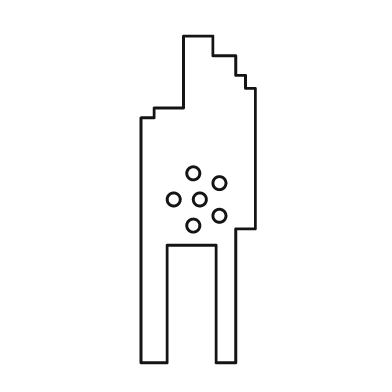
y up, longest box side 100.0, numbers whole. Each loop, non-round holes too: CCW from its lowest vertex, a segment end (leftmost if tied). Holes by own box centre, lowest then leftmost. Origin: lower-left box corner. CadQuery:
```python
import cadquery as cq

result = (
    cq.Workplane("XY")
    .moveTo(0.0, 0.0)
    .lineTo(8.0, 0.0)
    .lineTo(8.0, 36.0)
    .lineTo(23.0, 36.0)
    .lineTo(23.0, 0.0)
    .lineTo(29.0, 0.0)
    .lineTo(29.0, 41.0)
    .lineTo(35.0, 41.0)
    .lineTo(35.0, 84.0)
    .lineTo(32.0, 84.0)
    .lineTo(32.0, 88.0)
    .lineTo(29.0, 88.0)
    .lineTo(29.0, 94.0)
    .lineTo(22.0, 94.0)
    .lineTo(22.0, 100.0)
    .lineTo(13.0, 100.0)
    .lineTo(13.0, 78.0)
    .lineTo(4.0, 78.0)
    .lineTo(4.0, 75.0)
    .lineTo(0.0, 75.0)
    .close()
    .moveTo(16.0, 42.0)
    .circle(2.0)
    .moveTo(24.0, 45.0)
    .circle(2.0)
    .moveTo(10.0, 50.0)
    .circle(2.0)
    .moveTo(18.0, 50.0)
    .circle(2.0)
    .moveTo(24.0, 55.0)
    .circle(2.0)
    .moveTo(16.0, 58.0)
    .circle(2.0)
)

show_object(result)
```